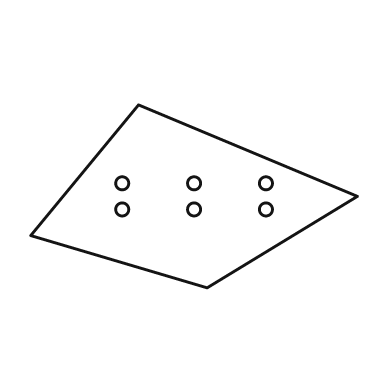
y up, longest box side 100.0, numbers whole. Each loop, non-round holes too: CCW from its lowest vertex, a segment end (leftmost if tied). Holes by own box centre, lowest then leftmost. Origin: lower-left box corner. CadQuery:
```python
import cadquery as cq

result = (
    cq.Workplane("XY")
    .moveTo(54.0, 0.0)
    .lineTo(100.0, 28.0)
    .lineTo(33.0, 56.0)
    .lineTo(0.0, 16.0)
    .close()
    .moveTo(28.0, 24.0)
    .circle(2.0)
    .moveTo(50.0, 24.0)
    .circle(2.0)
    .moveTo(72.0, 24.0)
    .circle(2.0)
    .moveTo(28.0, 32.0)
    .circle(2.0)
    .moveTo(50.0, 32.0)
    .circle(2.0)
    .moveTo(72.0, 32.0)
    .circle(2.0)
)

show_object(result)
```